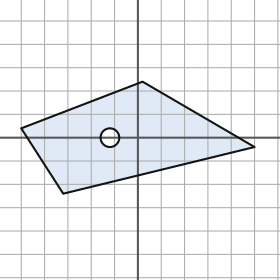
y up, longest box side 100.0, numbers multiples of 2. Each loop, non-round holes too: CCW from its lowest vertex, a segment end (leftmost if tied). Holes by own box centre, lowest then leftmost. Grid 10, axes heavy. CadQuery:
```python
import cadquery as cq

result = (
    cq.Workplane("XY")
    .moveTo(-32.0, -24.0)
    .lineTo(50.0, -4.0)
    .lineTo(2.0, 24.0)
    .lineTo(-50.0, 4.0)
    .close()
    .moveTo(-12.0, 0.0)
    .circle(4.0)
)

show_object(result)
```